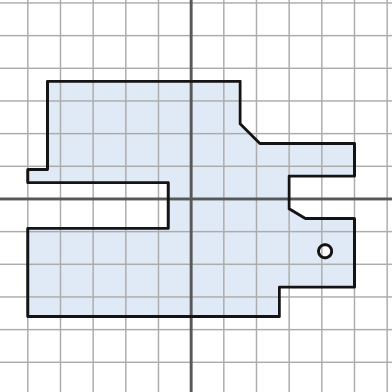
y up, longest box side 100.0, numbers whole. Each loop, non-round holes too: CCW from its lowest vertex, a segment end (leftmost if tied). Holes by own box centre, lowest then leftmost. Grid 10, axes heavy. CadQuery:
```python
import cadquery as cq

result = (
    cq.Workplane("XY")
    .moveTo(-50.0, -36.0)
    .lineTo(27.0, -36.0)
    .lineTo(27.0, -27.0)
    .lineTo(50.0, -27.0)
    .lineTo(50.0, -6.0)
    .lineTo(35.0, -6.0)
    .lineTo(30.0, -3.0)
    .lineTo(30.0, 7.0)
    .lineTo(50.0, 7.0)
    .lineTo(50.0, 17.0)
    .lineTo(21.0, 17.0)
    .lineTo(15.0, 23.0)
    .lineTo(15.0, 36.0)
    .lineTo(-44.0, 36.0)
    .lineTo(-44.0, 9.0)
    .lineTo(-50.0, 9.0)
    .lineTo(-50.0, 5.0)
    .lineTo(-7.0, 5.0)
    .lineTo(-7.0, -9.0)
    .lineTo(-50.0, -9.0)
    .close()
    .moveTo(41.0, -16.0)
    .circle(2.0)
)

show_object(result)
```